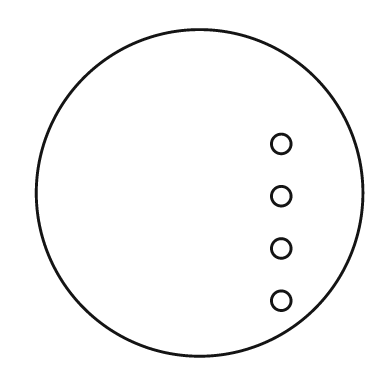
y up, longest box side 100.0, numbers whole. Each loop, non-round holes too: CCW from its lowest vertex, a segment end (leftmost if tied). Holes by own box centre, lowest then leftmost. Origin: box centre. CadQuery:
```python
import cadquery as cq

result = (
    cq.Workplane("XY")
    .moveTo(0.0, 0.0)
    .circle(50.0)
    .moveTo(25.0, -33.0)
    .circle(3.0)
    .moveTo(25.0, -17.0)
    .circle(3.0)
    .moveTo(25.0, -1.0)
    .circle(3.0)
    .moveTo(25.0, 15.0)
    .circle(3.0)
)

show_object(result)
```